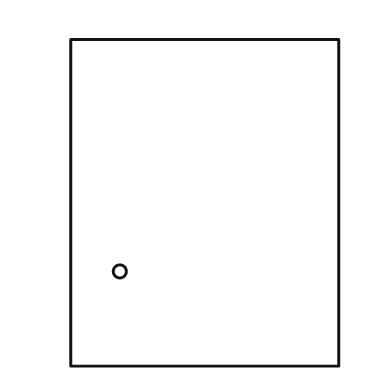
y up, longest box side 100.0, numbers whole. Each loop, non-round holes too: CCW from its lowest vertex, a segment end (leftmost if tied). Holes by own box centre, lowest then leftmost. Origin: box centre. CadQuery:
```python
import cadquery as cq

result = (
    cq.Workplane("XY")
    .moveTo(-41.0, -50.0)
    .lineTo(41.0, -50.0)
    .lineTo(41.0, 50.0)
    .lineTo(-41.0, 50.0)
    .close()
    .moveTo(-26.0, -21.0)
    .circle(2.0)
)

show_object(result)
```